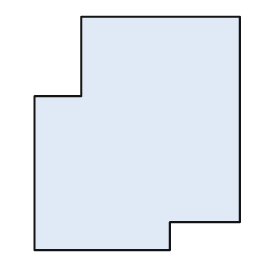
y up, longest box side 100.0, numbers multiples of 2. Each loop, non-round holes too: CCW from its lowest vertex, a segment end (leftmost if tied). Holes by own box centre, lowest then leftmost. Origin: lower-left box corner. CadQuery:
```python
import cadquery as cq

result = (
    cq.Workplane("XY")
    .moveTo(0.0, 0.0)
    .lineTo(58.0, 0.0)
    .lineTo(58.0, 12.0)
    .lineTo(88.0, 12.0)
    .lineTo(88.0, 100.0)
    .lineTo(20.0, 100.0)
    .lineTo(20.0, 66.0)
    .lineTo(0.0, 66.0)
    .close()
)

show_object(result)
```